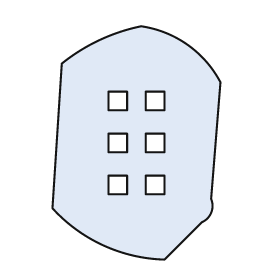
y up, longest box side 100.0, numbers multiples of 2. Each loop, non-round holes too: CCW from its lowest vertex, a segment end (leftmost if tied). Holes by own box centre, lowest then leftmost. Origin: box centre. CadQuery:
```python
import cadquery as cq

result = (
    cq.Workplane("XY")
    .moveTo(12.0, -50.0)
    .lineTo(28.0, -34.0)
    .threePointArc((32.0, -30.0), (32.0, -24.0))
    .lineTo(36.0, 26.0)
    .threePointArc((22.0, 42.0), (2.0, 50.0))
    .threePointArc((-16.0, 44.0), (-32.0, 34.0))
    .lineTo(-36.0, -28.0)
    .threePointArc((-14.0, -44.0), (12.0, -50.0))
    .close()
    .moveTo(-12.0, -22.0)
    .lineTo(-4.0, -22.0)
    .lineTo(-4.0, -14.0)
    .lineTo(-12.0, -14.0)
    .close()
    .moveTo(4.0, -22.0)
    .lineTo(12.0, -22.0)
    .lineTo(12.0, -14.0)
    .lineTo(4.0, -14.0)
    .close()
    .moveTo(-12.0, -4.0)
    .lineTo(-4.0, -4.0)
    .lineTo(-4.0, 4.0)
    .lineTo(-12.0, 4.0)
    .close()
    .moveTo(4.0, -4.0)
    .lineTo(12.0, -4.0)
    .lineTo(12.0, 4.0)
    .lineTo(4.0, 4.0)
    .close()
    .moveTo(-12.0, 14.0)
    .lineTo(-4.0, 14.0)
    .lineTo(-4.0, 22.0)
    .lineTo(-12.0, 22.0)
    .close()
    .moveTo(4.0, 14.0)
    .lineTo(12.0, 14.0)
    .lineTo(12.0, 22.0)
    .lineTo(4.0, 22.0)
    .close()
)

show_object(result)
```